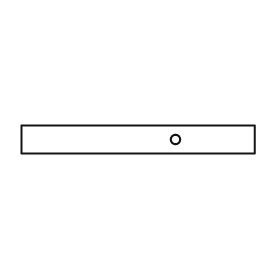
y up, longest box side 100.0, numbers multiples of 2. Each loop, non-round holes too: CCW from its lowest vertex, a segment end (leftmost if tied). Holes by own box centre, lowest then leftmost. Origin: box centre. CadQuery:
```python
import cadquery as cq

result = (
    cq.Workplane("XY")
    .moveTo(-50.0, -6.0)
    .lineTo(50.0, -6.0)
    .lineTo(50.0, 6.0)
    .lineTo(-50.0, 6.0)
    .close()
    .moveTo(16.0, 0.0)
    .circle(2.0)
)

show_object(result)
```